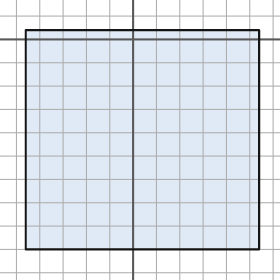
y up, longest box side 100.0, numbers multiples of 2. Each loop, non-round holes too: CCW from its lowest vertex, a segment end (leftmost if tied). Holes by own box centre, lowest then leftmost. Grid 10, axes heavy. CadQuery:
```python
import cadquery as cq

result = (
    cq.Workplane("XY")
    .moveTo(-46.0, -90.0)
    .lineTo(54.0, -90.0)
    .lineTo(54.0, 4.0)
    .lineTo(-46.0, 4.0)
    .close()
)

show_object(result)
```